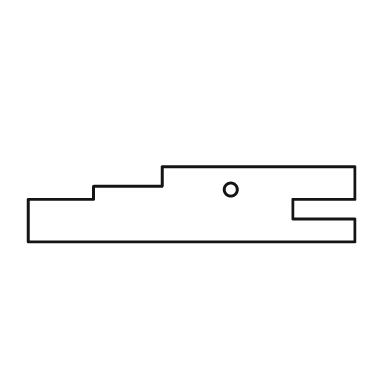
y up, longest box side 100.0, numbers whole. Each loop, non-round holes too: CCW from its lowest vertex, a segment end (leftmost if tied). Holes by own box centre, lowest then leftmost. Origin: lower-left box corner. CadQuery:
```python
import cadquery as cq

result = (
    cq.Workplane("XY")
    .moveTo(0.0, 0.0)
    .lineTo(100.0, 0.0)
    .lineTo(100.0, 7.0)
    .lineTo(81.0, 7.0)
    .lineTo(81.0, 13.0)
    .lineTo(100.0, 13.0)
    .lineTo(100.0, 23.0)
    .lineTo(41.0, 23.0)
    .lineTo(41.0, 17.0)
    .lineTo(20.0, 17.0)
    .lineTo(20.0, 13.0)
    .lineTo(0.0, 13.0)
    .close()
    .moveTo(62.0, 16.0)
    .circle(2.0)
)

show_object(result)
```